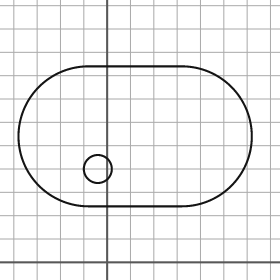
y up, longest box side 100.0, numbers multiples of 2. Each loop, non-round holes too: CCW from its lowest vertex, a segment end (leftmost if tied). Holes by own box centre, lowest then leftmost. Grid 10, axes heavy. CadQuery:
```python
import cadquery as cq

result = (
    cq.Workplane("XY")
    .moveTo(-8.0, 24.0)
    .lineTo(32.0, 24.0)
    .threePointArc((62.0, 54.0), (32.0, 84.0))
    .lineTo(-8.0, 84.0)
    .threePointArc((-38.0, 54.0), (-8.0, 24.0))
    .close()
    .moveTo(-4.0, 40.0)
    .circle(6.0)
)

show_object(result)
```